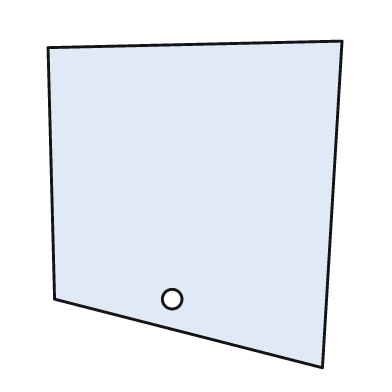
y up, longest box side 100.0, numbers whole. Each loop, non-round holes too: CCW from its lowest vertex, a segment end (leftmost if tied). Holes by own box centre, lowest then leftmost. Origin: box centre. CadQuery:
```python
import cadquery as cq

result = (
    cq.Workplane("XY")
    .moveTo(39.0, -50.0)
    .lineTo(45.0, 50.0)
    .lineTo(-45.0, 48.0)
    .lineTo(-43.0, -29.0)
    .close()
    .moveTo(-7.0, -29.0)
    .circle(3.0)
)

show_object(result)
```